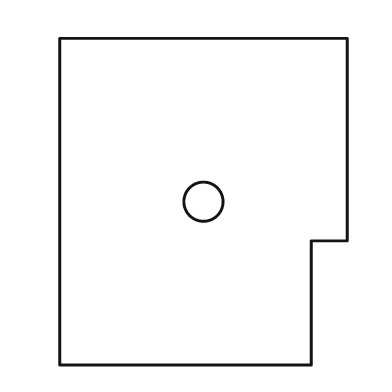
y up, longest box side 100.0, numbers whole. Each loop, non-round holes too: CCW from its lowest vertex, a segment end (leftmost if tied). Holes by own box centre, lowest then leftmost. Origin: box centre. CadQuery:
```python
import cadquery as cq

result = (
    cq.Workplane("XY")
    .moveTo(-44.0, -50.0)
    .lineTo(33.0, -50.0)
    .lineTo(33.0, -12.0)
    .lineTo(44.0, -12.0)
    .lineTo(44.0, 50.0)
    .lineTo(-44.0, 50.0)
    .close()
    .moveTo(0.0, 0.0)
    .circle(6.0)
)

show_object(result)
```